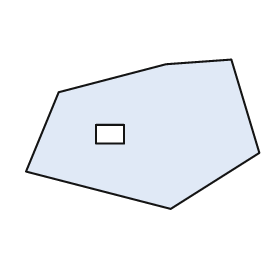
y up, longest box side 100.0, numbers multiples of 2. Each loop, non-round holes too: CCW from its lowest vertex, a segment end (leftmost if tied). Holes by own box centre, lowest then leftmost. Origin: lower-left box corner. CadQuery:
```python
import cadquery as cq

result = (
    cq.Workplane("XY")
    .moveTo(62.0, 0.0)
    .lineTo(100.0, 24.0)
    .lineTo(88.0, 64.0)
    .lineTo(60.0, 62.0)
    .lineTo(14.0, 50.0)
    .lineTo(0.0, 16.0)
    .close()
    .moveTo(30.0, 28.0)
    .lineTo(42.0, 28.0)
    .lineTo(42.0, 36.0)
    .lineTo(30.0, 36.0)
    .close()
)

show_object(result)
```